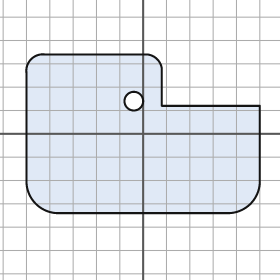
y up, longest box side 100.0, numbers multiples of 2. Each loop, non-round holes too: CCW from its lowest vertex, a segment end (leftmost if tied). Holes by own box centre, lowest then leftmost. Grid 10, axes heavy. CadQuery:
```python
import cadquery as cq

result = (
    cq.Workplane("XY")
    .moveTo(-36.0, -34.0)
    .lineTo(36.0, -34.0)
    .threePointArc((46.0, -30.0), (50.0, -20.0))
    .lineTo(50.0, 12.0)
    .lineTo(8.0, 12.0)
    .lineTo(8.0, 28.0)
    .threePointArc((6.0, 32.0), (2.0, 34.0))
    .lineTo(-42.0, 34.0)
    .threePointArc((-48.0, 32.0), (-50.0, 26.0))
    .lineTo(-50.0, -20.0)
    .threePointArc((-46.0, -30.0), (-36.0, -34.0))
    .close()
    .moveTo(-4.0, 14.0)
    .circle(4.0)
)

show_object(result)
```